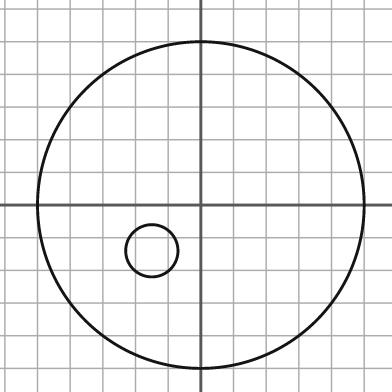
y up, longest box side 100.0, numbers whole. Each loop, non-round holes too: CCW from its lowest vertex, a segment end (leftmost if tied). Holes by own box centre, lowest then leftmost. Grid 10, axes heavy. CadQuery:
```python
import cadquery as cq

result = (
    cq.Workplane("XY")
    .moveTo(0.0, 0.0)
    .circle(50.0)
    .moveTo(-15.0, -14.0)
    .circle(8.0)
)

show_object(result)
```